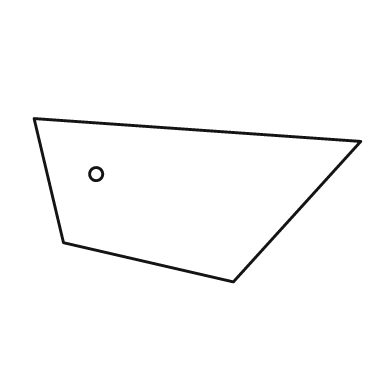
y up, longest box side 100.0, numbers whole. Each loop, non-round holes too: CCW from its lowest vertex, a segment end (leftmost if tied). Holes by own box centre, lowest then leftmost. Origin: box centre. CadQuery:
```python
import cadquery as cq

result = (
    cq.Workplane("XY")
    .moveTo(11.0, -25.0)
    .lineTo(50.0, 18.0)
    .lineTo(-50.0, 25.0)
    .lineTo(-41.0, -13.0)
    .close()
    .moveTo(-31.0, 8.0)
    .circle(2.0)
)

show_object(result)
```